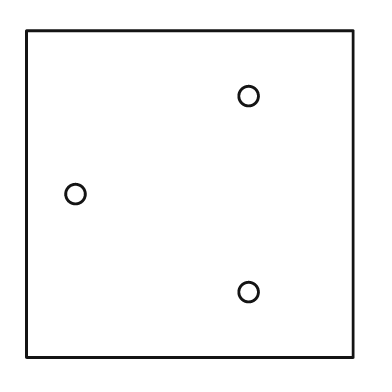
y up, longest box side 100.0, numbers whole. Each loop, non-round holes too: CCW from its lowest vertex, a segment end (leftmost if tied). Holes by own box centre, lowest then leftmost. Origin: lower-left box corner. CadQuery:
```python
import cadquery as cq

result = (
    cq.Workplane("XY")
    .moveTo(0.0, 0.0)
    .lineTo(100.0, 0.0)
    .lineTo(100.0, 100.0)
    .lineTo(0.0, 100.0)
    .close()
    .moveTo(68.0, 20.0)
    .circle(3.0)
    .moveTo(15.0, 50.0)
    .circle(3.0)
    .moveTo(68.0, 80.0)
    .circle(3.0)
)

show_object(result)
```